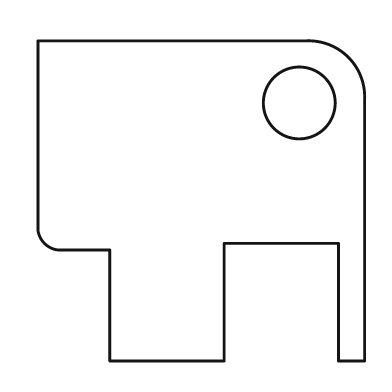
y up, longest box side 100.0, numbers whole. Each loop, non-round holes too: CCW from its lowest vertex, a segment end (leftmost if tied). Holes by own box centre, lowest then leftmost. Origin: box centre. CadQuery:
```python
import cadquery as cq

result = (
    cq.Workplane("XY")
    .moveTo(-28.0, -49.0)
    .lineTo(7.0, -49.0)
    .lineTo(7.0, -13.0)
    .lineTo(42.0, -13.0)
    .lineTo(42.0, -49.0)
    .lineTo(50.0, -49.0)
    .lineTo(50.0, 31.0)
    .threePointArc((45.0, 44.0), (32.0, 49.0))
    .lineTo(-50.0, 49.0)
    .lineTo(-50.0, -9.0)
    .threePointArc((-48.0, -13.0), (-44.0, -15.0))
    .lineTo(-28.0, -15.0)
    .close()
    .moveTo(30.0, 30.0)
    .circle(11.0)
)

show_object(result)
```